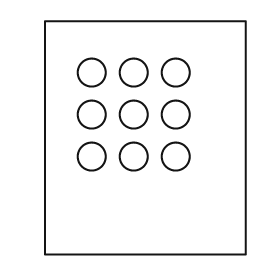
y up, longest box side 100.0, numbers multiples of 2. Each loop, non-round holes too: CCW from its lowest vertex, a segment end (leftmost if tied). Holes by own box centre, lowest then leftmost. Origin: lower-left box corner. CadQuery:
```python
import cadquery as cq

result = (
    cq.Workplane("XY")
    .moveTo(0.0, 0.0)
    .lineTo(86.0, 0.0)
    .lineTo(86.0, 100.0)
    .lineTo(0.0, 100.0)
    .close()
    .moveTo(20.0, 42.0)
    .circle(6.0)
    .moveTo(38.0, 42.0)
    .circle(6.0)
    .moveTo(56.0, 42.0)
    .circle(6.0)
    .moveTo(20.0, 60.0)
    .circle(6.0)
    .moveTo(38.0, 60.0)
    .circle(6.0)
    .moveTo(56.0, 60.0)
    .circle(6.0)
    .moveTo(20.0, 78.0)
    .circle(6.0)
    .moveTo(38.0, 78.0)
    .circle(6.0)
    .moveTo(56.0, 78.0)
    .circle(6.0)
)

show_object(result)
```